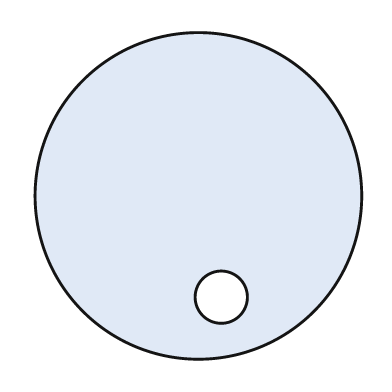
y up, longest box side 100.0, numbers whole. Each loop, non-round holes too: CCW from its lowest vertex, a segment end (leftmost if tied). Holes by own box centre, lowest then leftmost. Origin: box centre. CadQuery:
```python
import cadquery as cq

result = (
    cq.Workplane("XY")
    .moveTo(0.0, 0.0)
    .circle(50.0)
    .moveTo(7.0, -31.0)
    .circle(8.0)
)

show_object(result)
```